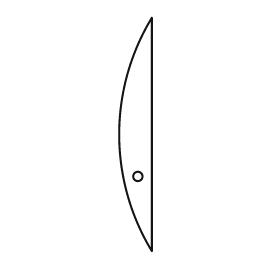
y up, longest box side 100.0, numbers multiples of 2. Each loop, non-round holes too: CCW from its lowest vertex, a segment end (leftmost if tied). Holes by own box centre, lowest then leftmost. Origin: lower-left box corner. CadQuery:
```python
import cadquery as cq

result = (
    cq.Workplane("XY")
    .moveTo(14.0, 0.0)
    .lineTo(14.0, 100.0)
    .threePointArc((0.0, 50.0), (14.0, 0.0))
    .close()
    .moveTo(8.0, 32.0)
    .circle(2.0)
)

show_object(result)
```